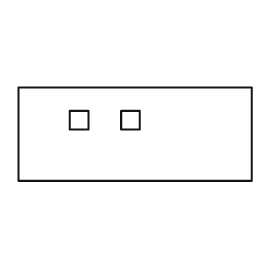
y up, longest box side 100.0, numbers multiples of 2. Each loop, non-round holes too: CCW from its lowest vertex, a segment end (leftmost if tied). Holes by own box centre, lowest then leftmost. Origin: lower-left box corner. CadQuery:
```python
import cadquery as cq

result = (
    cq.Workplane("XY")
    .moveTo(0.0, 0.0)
    .lineTo(100.0, 0.0)
    .lineTo(100.0, 40.0)
    .lineTo(0.0, 40.0)
    .close()
    .moveTo(22.0, 22.0)
    .lineTo(30.0, 22.0)
    .lineTo(30.0, 30.0)
    .lineTo(22.0, 30.0)
    .close()
    .moveTo(44.0, 22.0)
    .lineTo(52.0, 22.0)
    .lineTo(52.0, 30.0)
    .lineTo(44.0, 30.0)
    .close()
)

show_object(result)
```